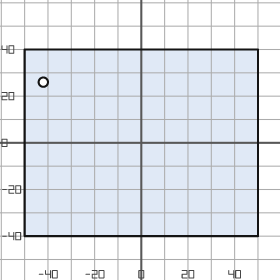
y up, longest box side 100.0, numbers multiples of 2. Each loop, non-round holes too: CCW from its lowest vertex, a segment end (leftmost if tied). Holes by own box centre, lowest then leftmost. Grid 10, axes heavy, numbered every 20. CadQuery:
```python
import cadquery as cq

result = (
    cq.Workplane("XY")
    .moveTo(-50.0, -40.0)
    .lineTo(50.0, -40.0)
    .lineTo(50.0, 40.0)
    .lineTo(-50.0, 40.0)
    .close()
    .moveTo(-42.0, 26.0)
    .circle(2.0)
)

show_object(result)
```